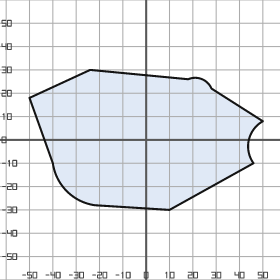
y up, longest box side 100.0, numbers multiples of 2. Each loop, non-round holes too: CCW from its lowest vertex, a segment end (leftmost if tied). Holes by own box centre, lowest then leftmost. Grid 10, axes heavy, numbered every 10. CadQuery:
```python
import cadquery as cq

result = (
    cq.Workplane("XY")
    .moveTo(10.0, -30.0)
    .lineTo(46.0, -10.0)
    .threePointArc((44.0, 0.0), (50.0, 8.0))
    .lineTo(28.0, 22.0)
    .threePointArc((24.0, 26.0), (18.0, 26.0))
    .lineTo(-24.0, 30.0)
    .lineTo(-50.0, 18.0)
    .lineTo(-40.0, -10.0)
    .threePointArc((-34.0, -22.0), (-22.0, -28.0))
    .close()
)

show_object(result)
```